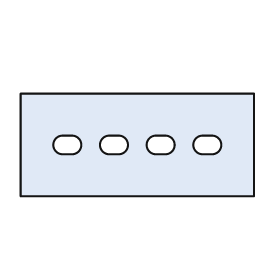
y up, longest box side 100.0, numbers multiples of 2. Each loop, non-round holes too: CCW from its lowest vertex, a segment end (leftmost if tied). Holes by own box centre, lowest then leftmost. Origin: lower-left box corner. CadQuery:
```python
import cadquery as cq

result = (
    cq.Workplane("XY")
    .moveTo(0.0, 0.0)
    .lineTo(100.0, 0.0)
    .lineTo(100.0, 44.0)
    .lineTo(0.0, 44.0)
    .close()
    .moveTo(18.0, 18.0)
    .lineTo(22.0, 18.0)
    .threePointArc((26.0, 22.0), (22.0, 26.0))
    .lineTo(18.0, 26.0)
    .threePointArc((14.0, 22.0), (18.0, 18.0))
    .close()
    .moveTo(38.0, 18.0)
    .lineTo(42.0, 18.0)
    .threePointArc((46.0, 22.0), (42.0, 26.0))
    .lineTo(38.0, 26.0)
    .threePointArc((34.0, 22.0), (38.0, 18.0))
    .close()
    .moveTo(58.0, 18.0)
    .lineTo(62.0, 18.0)
    .threePointArc((66.0, 22.0), (62.0, 26.0))
    .lineTo(58.0, 26.0)
    .threePointArc((54.0, 22.0), (58.0, 18.0))
    .close()
    .moveTo(78.0, 18.0)
    .lineTo(82.0, 18.0)
    .threePointArc((86.0, 22.0), (82.0, 26.0))
    .lineTo(78.0, 26.0)
    .threePointArc((74.0, 22.0), (78.0, 18.0))
    .close()
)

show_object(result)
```